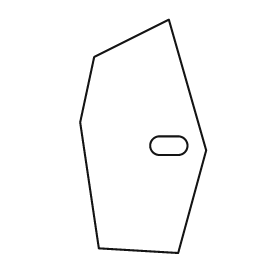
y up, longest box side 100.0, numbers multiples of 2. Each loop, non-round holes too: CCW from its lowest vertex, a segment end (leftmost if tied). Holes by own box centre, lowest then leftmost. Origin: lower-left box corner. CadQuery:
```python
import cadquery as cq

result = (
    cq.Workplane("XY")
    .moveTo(42.0, 0.0)
    .lineTo(54.0, 44.0)
    .lineTo(38.0, 100.0)
    .lineTo(6.0, 84.0)
    .lineTo(0.0, 56.0)
    .lineTo(8.0, 2.0)
    .close()
    .moveTo(34.0, 42.0)
    .lineTo(42.0, 42.0)
    .threePointArc((46.0, 46.0), (42.0, 50.0))
    .lineTo(34.0, 50.0)
    .threePointArc((30.0, 46.0), (34.0, 42.0))
    .close()
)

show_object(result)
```